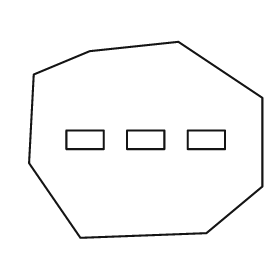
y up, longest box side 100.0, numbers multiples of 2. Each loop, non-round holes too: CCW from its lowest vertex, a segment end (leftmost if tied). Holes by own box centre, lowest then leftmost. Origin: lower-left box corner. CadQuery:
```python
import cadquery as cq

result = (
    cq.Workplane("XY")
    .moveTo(22.0, 0.0)
    .lineTo(76.0, 2.0)
    .lineTo(100.0, 22.0)
    .lineTo(100.0, 60.0)
    .lineTo(64.0, 84.0)
    .lineTo(26.0, 80.0)
    .lineTo(2.0, 70.0)
    .lineTo(0.0, 32.0)
    .close()
    .moveTo(16.0, 38.0)
    .lineTo(32.0, 38.0)
    .lineTo(32.0, 46.0)
    .lineTo(16.0, 46.0)
    .close()
    .moveTo(42.0, 38.0)
    .lineTo(58.0, 38.0)
    .lineTo(58.0, 46.0)
    .lineTo(42.0, 46.0)
    .close()
    .moveTo(68.0, 38.0)
    .lineTo(84.0, 38.0)
    .lineTo(84.0, 46.0)
    .lineTo(68.0, 46.0)
    .close()
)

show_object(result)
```